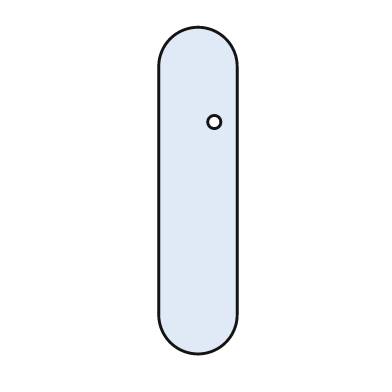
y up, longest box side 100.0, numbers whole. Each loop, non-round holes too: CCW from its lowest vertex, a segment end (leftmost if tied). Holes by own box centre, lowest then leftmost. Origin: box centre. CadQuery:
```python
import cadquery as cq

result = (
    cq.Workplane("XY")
    .moveTo(-12.0, -38.0)
    .threePointArc((0.0, -50.0), (12.0, -38.0))
    .lineTo(12.0, 38.0)
    .threePointArc((0.0, 50.0), (-12.0, 38.0))
    .close()
    .moveTo(5.0, 21.0)
    .circle(2.0)
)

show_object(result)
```